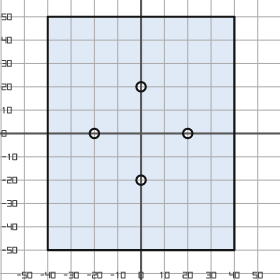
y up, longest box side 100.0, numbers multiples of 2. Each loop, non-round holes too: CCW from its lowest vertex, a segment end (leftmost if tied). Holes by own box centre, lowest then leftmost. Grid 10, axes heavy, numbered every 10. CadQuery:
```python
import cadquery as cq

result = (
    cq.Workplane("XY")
    .moveTo(-40.0, -50.0)
    .lineTo(40.0, -50.0)
    .lineTo(40.0, 50.0)
    .lineTo(-40.0, 50.0)
    .close()
    .moveTo(0.0, -20.0)
    .circle(2.0)
    .moveTo(-20.0, 0.0)
    .circle(2.0)
    .moveTo(20.0, 0.0)
    .circle(2.0)
    .moveTo(0.0, 20.0)
    .circle(2.0)
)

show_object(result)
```